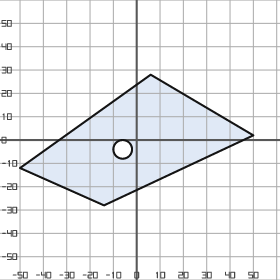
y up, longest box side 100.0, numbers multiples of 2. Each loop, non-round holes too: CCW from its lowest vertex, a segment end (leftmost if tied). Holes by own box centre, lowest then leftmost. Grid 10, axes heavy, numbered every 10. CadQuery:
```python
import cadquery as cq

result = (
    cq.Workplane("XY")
    .moveTo(-14.0, -28.0)
    .lineTo(50.0, 2.0)
    .lineTo(6.0, 28.0)
    .lineTo(-50.0, -12.0)
    .close()
    .moveTo(-6.0, -4.0)
    .circle(4.0)
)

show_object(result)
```